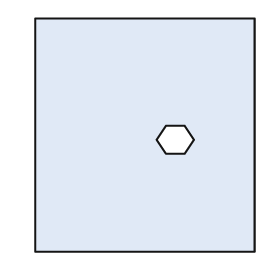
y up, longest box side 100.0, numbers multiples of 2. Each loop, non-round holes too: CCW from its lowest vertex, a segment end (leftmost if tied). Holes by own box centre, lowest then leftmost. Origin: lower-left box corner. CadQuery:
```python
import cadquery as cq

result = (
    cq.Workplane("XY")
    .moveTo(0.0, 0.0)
    .lineTo(94.0, 0.0)
    .lineTo(94.0, 100.0)
    .lineTo(0.0, 100.0)
    .close()
    .moveTo(56.0, 42.0)
    .lineTo(64.0, 42.0)
    .lineTo(68.0, 48.0)
    .lineTo(64.0, 54.0)
    .lineTo(56.0, 54.0)
    .lineTo(52.0, 48.0)
    .close()
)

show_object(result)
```